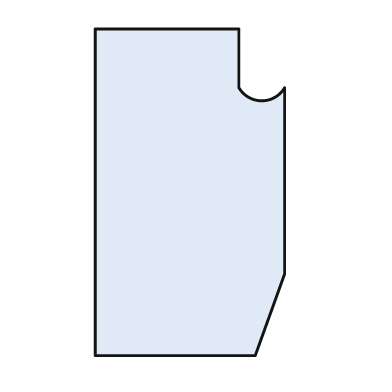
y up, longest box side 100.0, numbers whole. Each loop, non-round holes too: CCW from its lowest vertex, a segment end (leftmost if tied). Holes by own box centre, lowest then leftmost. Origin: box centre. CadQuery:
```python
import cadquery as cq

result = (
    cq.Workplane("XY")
    .moveTo(-29.0, -50.0)
    .lineTo(20.0, -50.0)
    .lineTo(29.0, -25.0)
    .lineTo(29.0, 32.0)
    .threePointArc((22.0, 28.0), (15.0, 32.0))
    .lineTo(15.0, 50.0)
    .lineTo(-29.0, 50.0)
    .close()
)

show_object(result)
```